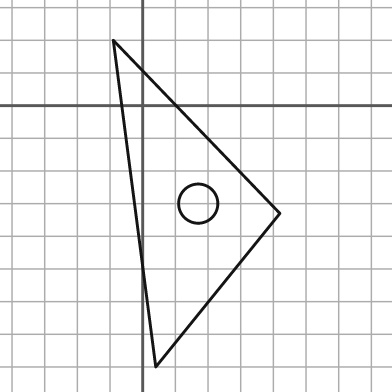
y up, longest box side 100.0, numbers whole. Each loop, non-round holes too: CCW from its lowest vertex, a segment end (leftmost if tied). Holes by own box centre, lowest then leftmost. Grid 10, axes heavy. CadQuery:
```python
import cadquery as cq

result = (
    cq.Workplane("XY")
    .moveTo(4.0, -80.0)
    .lineTo(42.0, -33.0)
    .lineTo(-9.0, 20.0)
    .close()
    .moveTo(17.0, -30.0)
    .circle(6.0)
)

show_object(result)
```